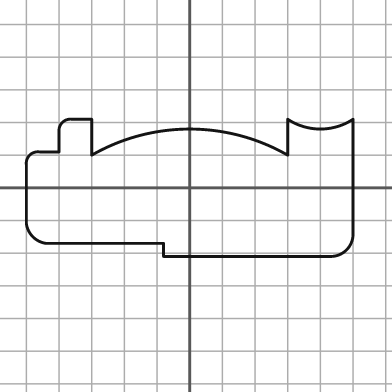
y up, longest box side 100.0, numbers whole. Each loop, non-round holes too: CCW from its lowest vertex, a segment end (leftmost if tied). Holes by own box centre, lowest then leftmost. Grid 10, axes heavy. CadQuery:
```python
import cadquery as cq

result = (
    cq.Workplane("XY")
    .moveTo(-8.0, -21.0)
    .lineTo(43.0, -21.0)
    .threePointArc((48.0, -19.0), (50.0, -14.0))
    .lineTo(50.0, 21.0)
    .threePointArc((40.0, 18.0), (30.0, 21.0))
    .lineTo(30.0, 10.0)
    .threePointArc((0.0, 18.0), (-30.0, 10.0))
    .lineTo(-30.0, 21.0)
    .lineTo(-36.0, 21.0)
    .threePointArc((-39.0, 20.0), (-40.0, 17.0))
    .lineTo(-40.0, 11.0)
    .lineTo(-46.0, 11.0)
    .threePointArc((-49.0, 10.0), (-50.0, 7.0))
    .lineTo(-50.0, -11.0)
    .threePointArc((-48.0, -15.0), (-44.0, -17.0))
    .lineTo(-8.0, -17.0)
    .close()
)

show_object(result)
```